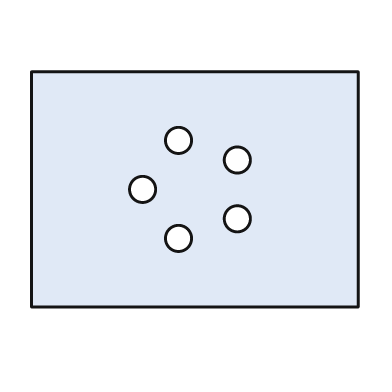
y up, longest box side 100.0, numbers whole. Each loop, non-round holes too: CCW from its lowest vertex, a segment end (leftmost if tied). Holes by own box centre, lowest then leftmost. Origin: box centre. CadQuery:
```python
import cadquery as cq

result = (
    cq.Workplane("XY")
    .moveTo(-50.0, -36.0)
    .lineTo(50.0, -36.0)
    .lineTo(50.0, 36.0)
    .lineTo(-50.0, 36.0)
    .close()
    .moveTo(-5.0, -15.0)
    .circle(4.0)
    .moveTo(13.0, -9.0)
    .circle(4.0)
    .moveTo(-16.0, 0.0)
    .circle(4.0)
    .moveTo(13.0, 9.0)
    .circle(4.0)
    .moveTo(-5.0, 15.0)
    .circle(4.0)
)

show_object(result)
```